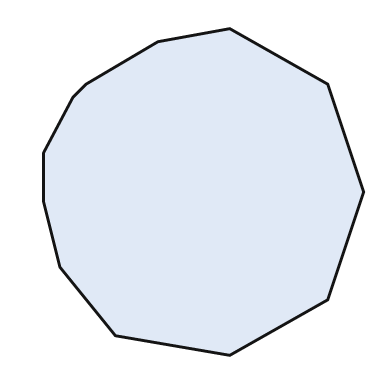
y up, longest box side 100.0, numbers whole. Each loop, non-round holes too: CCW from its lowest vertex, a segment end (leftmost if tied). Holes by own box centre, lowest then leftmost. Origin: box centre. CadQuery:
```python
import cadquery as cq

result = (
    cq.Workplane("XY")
    .moveTo(8.0, -50.0)
    .lineTo(38.0, -33.0)
    .lineTo(49.0, 0.0)
    .lineTo(38.0, 33.0)
    .lineTo(8.0, 50.0)
    .lineTo(-14.0, 46.0)
    .lineTo(-36.0, 33.0)
    .lineTo(-40.0, 29.0)
    .lineTo(-49.0, 12.0)
    .lineTo(-49.0, -3.0)
    .lineTo(-44.0, -23.0)
    .lineTo(-27.0, -44.0)
    .close()
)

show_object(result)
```